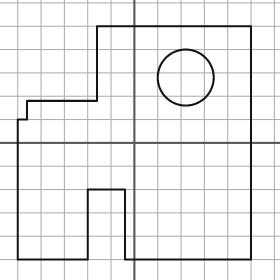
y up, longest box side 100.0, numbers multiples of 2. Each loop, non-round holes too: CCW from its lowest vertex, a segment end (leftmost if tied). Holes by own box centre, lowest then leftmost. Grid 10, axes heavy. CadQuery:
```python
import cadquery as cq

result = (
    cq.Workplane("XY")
    .moveTo(-50.0, -50.0)
    .lineTo(-20.0, -50.0)
    .lineTo(-20.0, -20.0)
    .lineTo(-4.0, -20.0)
    .lineTo(-4.0, -50.0)
    .lineTo(50.0, -50.0)
    .lineTo(50.0, 50.0)
    .lineTo(-16.0, 50.0)
    .lineTo(-16.0, 18.0)
    .lineTo(-46.0, 18.0)
    .lineTo(-46.0, 10.0)
    .lineTo(-50.0, 10.0)
    .close()
    .moveTo(22.0, 28.0)
    .circle(12.0)
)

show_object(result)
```